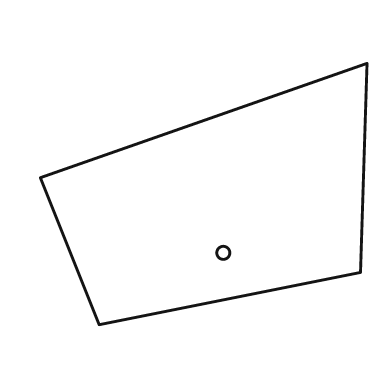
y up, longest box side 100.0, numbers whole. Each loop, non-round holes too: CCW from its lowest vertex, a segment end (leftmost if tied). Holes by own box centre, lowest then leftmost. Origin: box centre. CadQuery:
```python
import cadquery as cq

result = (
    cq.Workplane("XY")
    .moveTo(-32.0, -40.0)
    .lineTo(48.0, -24.0)
    .lineTo(50.0, 40.0)
    .lineTo(-50.0, 5.0)
    .close()
    .moveTo(6.0, -18.0)
    .circle(2.0)
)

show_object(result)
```